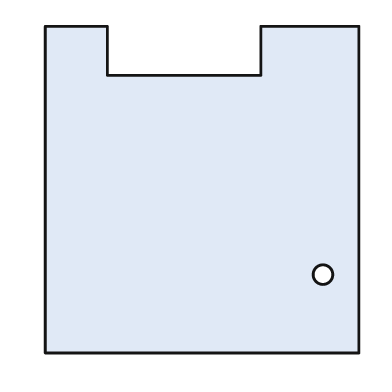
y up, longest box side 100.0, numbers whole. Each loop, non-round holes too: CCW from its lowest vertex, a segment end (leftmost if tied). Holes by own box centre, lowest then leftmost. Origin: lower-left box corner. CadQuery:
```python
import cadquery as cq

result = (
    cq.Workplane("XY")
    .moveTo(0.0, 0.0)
    .lineTo(96.0, 0.0)
    .lineTo(96.0, 100.0)
    .lineTo(66.0, 100.0)
    .lineTo(66.0, 85.0)
    .lineTo(19.0, 85.0)
    .lineTo(19.0, 100.0)
    .lineTo(0.0, 100.0)
    .close()
    .moveTo(85.0, 24.0)
    .circle(3.0)
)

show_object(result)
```